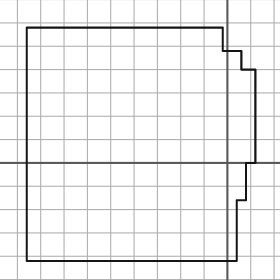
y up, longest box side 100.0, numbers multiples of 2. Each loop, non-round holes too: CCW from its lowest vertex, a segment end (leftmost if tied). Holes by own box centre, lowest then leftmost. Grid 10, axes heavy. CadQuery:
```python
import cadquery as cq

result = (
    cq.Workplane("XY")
    .moveTo(-86.0, -42.0)
    .lineTo(4.0, -42.0)
    .lineTo(4.0, -16.0)
    .lineTo(8.0, -16.0)
    .lineTo(8.0, 0.0)
    .lineTo(12.0, 0.0)
    .lineTo(12.0, 40.0)
    .lineTo(6.0, 40.0)
    .lineTo(6.0, 48.0)
    .lineTo(-2.0, 48.0)
    .lineTo(-2.0, 58.0)
    .lineTo(-86.0, 58.0)
    .close()
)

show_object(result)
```